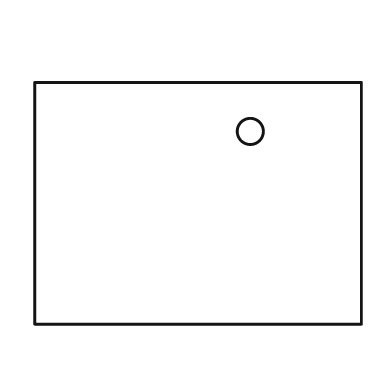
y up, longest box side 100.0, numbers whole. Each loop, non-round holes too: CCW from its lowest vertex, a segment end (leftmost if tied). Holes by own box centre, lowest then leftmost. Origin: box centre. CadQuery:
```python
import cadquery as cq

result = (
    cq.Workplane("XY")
    .moveTo(-50.0, -37.0)
    .lineTo(50.0, -37.0)
    .lineTo(50.0, 37.0)
    .lineTo(-50.0, 37.0)
    .close()
    .moveTo(16.0, 22.0)
    .circle(4.0)
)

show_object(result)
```